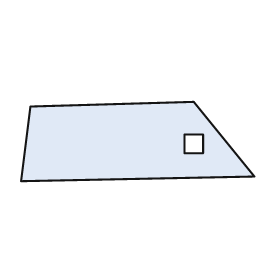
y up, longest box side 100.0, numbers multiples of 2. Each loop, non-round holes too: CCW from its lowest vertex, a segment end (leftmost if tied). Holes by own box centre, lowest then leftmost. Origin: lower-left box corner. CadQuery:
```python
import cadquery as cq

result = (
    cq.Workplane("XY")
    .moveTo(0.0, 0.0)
    .lineTo(100.0, 2.0)
    .lineTo(74.0, 34.0)
    .lineTo(4.0, 32.0)
    .close()
    .moveTo(70.0, 12.0)
    .lineTo(78.0, 12.0)
    .lineTo(78.0, 20.0)
    .lineTo(70.0, 20.0)
    .close()
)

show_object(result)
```